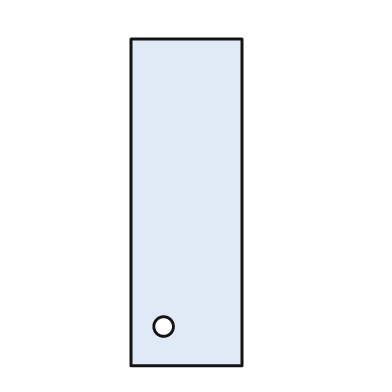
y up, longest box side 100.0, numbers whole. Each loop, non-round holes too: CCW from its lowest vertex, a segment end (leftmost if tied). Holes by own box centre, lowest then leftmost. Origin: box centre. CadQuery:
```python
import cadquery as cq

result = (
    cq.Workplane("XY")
    .moveTo(-17.0, -50.0)
    .lineTo(17.0, -50.0)
    .lineTo(17.0, 50.0)
    .lineTo(-17.0, 50.0)
    .close()
    .moveTo(-7.0, -38.0)
    .circle(3.0)
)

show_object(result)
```